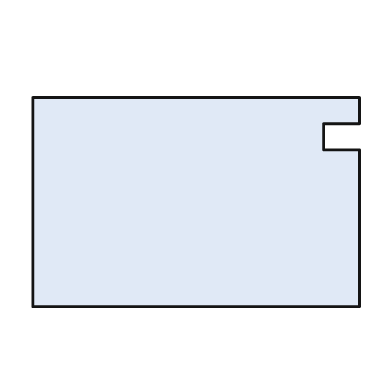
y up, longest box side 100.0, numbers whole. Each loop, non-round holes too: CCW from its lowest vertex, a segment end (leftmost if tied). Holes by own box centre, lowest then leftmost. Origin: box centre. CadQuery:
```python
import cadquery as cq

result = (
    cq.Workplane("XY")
    .moveTo(-50.0, -32.0)
    .lineTo(50.0, -32.0)
    .lineTo(50.0, 16.0)
    .lineTo(39.0, 16.0)
    .lineTo(39.0, 24.0)
    .lineTo(50.0, 24.0)
    .lineTo(50.0, 32.0)
    .lineTo(-50.0, 32.0)
    .close()
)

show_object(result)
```